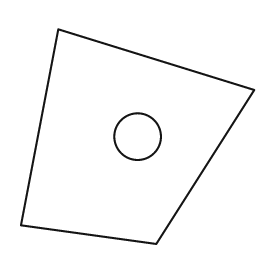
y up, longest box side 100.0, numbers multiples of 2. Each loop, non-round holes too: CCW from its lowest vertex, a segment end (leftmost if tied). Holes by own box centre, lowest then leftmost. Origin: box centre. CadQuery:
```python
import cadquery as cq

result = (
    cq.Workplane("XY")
    .moveTo(8.0, -46.0)
    .lineTo(50.0, 20.0)
    .lineTo(-34.0, 46.0)
    .lineTo(-50.0, -38.0)
    .close()
    .moveTo(0.0, 0.0)
    .circle(10.0)
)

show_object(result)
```